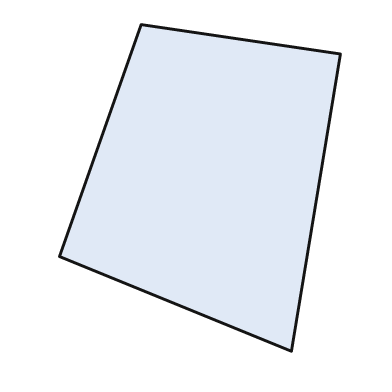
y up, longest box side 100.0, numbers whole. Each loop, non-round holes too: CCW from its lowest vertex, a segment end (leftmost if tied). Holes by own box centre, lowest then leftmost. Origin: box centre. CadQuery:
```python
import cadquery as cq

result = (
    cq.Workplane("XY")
    .moveTo(28.0, -50.0)
    .lineTo(43.0, 41.0)
    .lineTo(-18.0, 50.0)
    .lineTo(-43.0, -21.0)
    .close()
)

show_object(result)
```